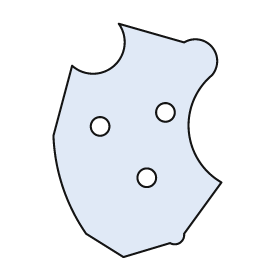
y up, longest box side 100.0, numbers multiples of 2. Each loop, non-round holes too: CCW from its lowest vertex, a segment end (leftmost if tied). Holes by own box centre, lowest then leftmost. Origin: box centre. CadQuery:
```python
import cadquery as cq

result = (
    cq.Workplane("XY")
    .moveTo(-6.0, -50.0)
    .lineTo(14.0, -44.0)
    .threePointArc((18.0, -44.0), (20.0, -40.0))
    .lineTo(36.0, -18.0)
    .threePointArc((22.0, 4.0), (32.0, 28.0))
    .threePointArc((32.0, 40.0), (20.0, 42.0))
    .lineTo(-8.0, 50.0)
    .threePointArc((-10.0, 32.0), (-28.0, 32.0))
    .lineTo(-36.0, 2.0)
    .threePointArc((-32.0, -20.0), (-22.0, -40.0))
    .close()
    .moveTo(4.0, -16.0)
    .circle(4.0)
    .moveTo(-16.0, 6.0)
    .circle(4.0)
    .moveTo(12.0, 12.0)
    .circle(4.0)
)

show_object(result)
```